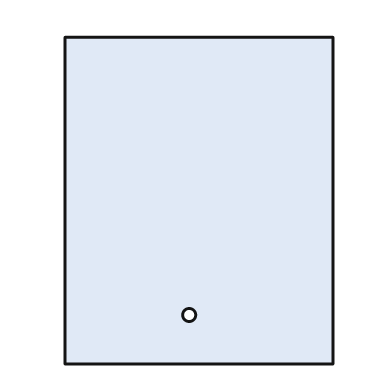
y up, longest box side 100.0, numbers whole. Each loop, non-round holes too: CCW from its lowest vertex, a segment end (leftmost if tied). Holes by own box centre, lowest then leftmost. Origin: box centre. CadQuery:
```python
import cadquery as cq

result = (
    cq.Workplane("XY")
    .moveTo(-41.0, -50.0)
    .lineTo(41.0, -50.0)
    .lineTo(41.0, 50.0)
    .lineTo(-41.0, 50.0)
    .close()
    .moveTo(-3.0, -35.0)
    .circle(2.0)
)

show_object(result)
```